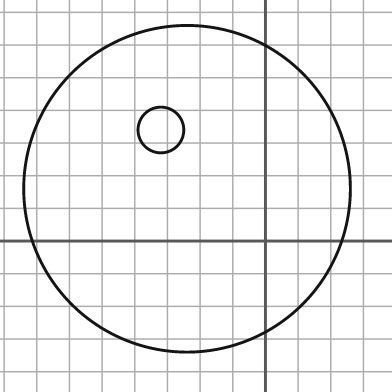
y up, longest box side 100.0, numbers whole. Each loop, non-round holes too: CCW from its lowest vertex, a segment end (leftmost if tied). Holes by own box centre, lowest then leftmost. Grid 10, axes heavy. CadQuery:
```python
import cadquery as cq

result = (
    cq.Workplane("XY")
    .moveTo(-24.0, 16.0)
    .circle(50.0)
    .moveTo(-32.0, 34.0)
    .circle(7.0)
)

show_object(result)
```